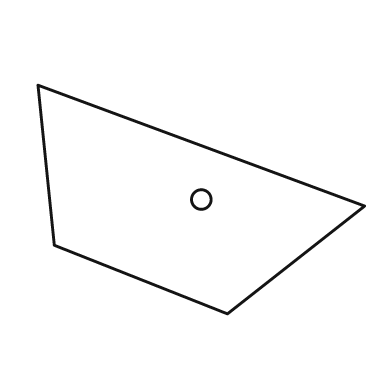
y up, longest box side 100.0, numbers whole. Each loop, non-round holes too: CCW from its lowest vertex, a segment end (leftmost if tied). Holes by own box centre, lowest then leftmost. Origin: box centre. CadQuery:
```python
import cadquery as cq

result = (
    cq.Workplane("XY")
    .moveTo(8.0, -35.0)
    .lineTo(50.0, -2.0)
    .lineTo(-50.0, 35.0)
    .lineTo(-45.0, -14.0)
    .close()
    .moveTo(0.0, 0.0)
    .circle(3.0)
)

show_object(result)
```